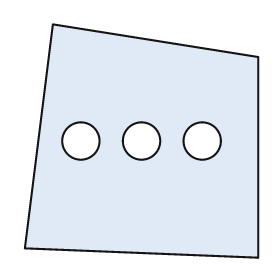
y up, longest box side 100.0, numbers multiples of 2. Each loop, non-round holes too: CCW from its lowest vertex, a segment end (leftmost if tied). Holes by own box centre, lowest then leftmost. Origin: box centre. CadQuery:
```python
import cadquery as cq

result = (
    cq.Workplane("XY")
    .moveTo(50.0, -50.0)
    .lineTo(50.0, 36.0)
    .lineTo(-38.0, 50.0)
    .lineTo(-50.0, -46.0)
    .close()
    .moveTo(-26.0, 0.0)
    .circle(8.0)
    .moveTo(0.0, 0.0)
    .circle(8.0)
    .moveTo(26.0, 0.0)
    .circle(8.0)
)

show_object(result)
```